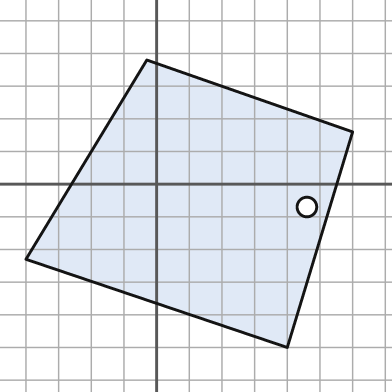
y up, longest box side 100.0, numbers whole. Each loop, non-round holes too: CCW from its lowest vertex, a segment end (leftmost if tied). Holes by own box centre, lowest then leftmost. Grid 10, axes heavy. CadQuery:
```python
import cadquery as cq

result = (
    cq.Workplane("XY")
    .moveTo(40.0, -50.0)
    .lineTo(60.0, 16.0)
    .lineTo(-3.0, 38.0)
    .lineTo(-40.0, -23.0)
    .close()
    .moveTo(46.0, -7.0)
    .circle(3.0)
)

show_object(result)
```